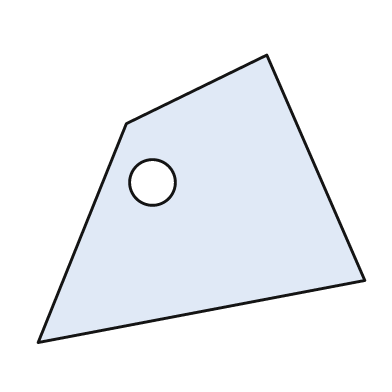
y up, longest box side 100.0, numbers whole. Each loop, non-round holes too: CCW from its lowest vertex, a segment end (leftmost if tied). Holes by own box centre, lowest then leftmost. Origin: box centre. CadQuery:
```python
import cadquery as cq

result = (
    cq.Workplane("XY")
    .moveTo(-50.0, -44.0)
    .lineTo(50.0, -25.0)
    .lineTo(20.0, 44.0)
    .lineTo(-23.0, 23.0)
    .close()
    .moveTo(-15.0, 5.0)
    .circle(7.0)
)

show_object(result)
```